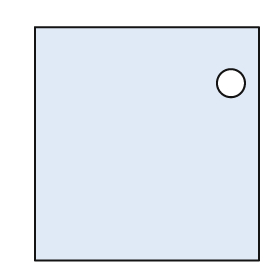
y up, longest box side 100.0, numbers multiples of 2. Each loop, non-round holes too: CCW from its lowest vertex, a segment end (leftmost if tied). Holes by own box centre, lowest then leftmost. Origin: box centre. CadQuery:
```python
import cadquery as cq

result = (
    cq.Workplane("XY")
    .moveTo(-48.0, -50.0)
    .lineTo(48.0, -50.0)
    .lineTo(48.0, 50.0)
    .lineTo(-48.0, 50.0)
    .close()
    .moveTo(36.0, 26.0)
    .circle(6.0)
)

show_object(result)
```